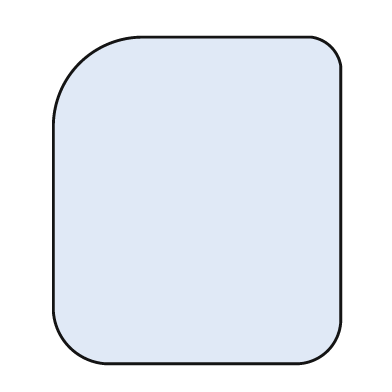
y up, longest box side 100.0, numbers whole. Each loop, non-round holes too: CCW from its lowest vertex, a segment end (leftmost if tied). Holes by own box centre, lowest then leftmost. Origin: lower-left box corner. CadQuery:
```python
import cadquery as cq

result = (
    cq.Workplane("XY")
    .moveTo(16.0, 0.0)
    .lineTo(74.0, 0.0)
    .threePointArc((84.0, 4.0), (88.0, 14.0))
    .lineTo(88.0, 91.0)
    .threePointArc((85.0, 97.0), (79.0, 100.0))
    .lineTo(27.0, 100.0)
    .threePointArc((8.0, 92.0), (0.0, 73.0))
    .lineTo(0.0, 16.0)
    .threePointArc((5.0, 5.0), (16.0, 0.0))
    .close()
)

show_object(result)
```